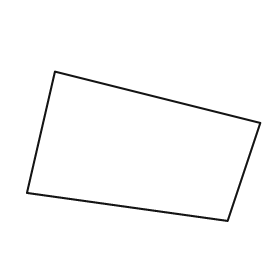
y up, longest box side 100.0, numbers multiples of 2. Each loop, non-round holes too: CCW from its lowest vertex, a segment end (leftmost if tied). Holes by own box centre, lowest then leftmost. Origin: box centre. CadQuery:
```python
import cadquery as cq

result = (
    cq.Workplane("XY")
    .moveTo(36.0, -32.0)
    .lineTo(50.0, 10.0)
    .lineTo(-38.0, 32.0)
    .lineTo(-50.0, -20.0)
    .close()
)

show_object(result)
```